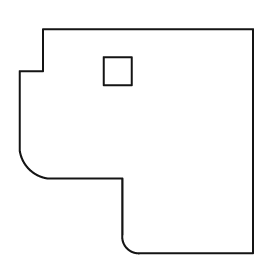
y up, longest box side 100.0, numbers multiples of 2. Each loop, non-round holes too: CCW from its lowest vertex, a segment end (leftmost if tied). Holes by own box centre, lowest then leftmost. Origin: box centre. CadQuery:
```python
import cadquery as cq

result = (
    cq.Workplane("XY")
    .moveTo(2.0, -48.0)
    .lineTo(50.0, -48.0)
    .lineTo(50.0, 48.0)
    .lineTo(-40.0, 48.0)
    .lineTo(-40.0, 30.0)
    .lineTo(-50.0, 30.0)
    .lineTo(-50.0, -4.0)
    .threePointArc((-46.0, -12.0), (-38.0, -16.0))
    .lineTo(-6.0, -16.0)
    .lineTo(-6.0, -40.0)
    .threePointArc((-4.0, -46.0), (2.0, -48.0))
    .close()
    .moveTo(-14.0, 24.0)
    .lineTo(-2.0, 24.0)
    .lineTo(-2.0, 36.0)
    .lineTo(-14.0, 36.0)
    .close()
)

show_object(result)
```